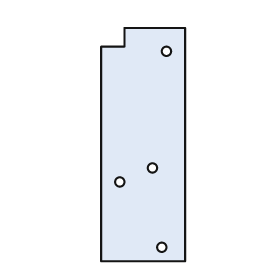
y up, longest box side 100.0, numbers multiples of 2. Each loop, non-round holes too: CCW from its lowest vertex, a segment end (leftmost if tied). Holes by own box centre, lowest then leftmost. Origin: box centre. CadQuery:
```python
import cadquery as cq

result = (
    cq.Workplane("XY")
    .moveTo(-18.0, -50.0)
    .lineTo(18.0, -50.0)
    .lineTo(18.0, 50.0)
    .lineTo(-8.0, 50.0)
    .lineTo(-8.0, 42.0)
    .lineTo(-18.0, 42.0)
    .close()
    .moveTo(8.0, -44.0)
    .circle(2.0)
    .moveTo(-10.0, -16.0)
    .circle(2.0)
    .moveTo(4.0, -10.0)
    .circle(2.0)
    .moveTo(10.0, 40.0)
    .circle(2.0)
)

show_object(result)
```